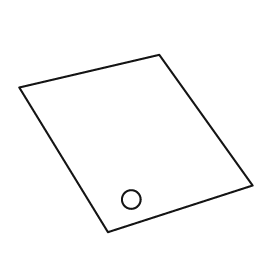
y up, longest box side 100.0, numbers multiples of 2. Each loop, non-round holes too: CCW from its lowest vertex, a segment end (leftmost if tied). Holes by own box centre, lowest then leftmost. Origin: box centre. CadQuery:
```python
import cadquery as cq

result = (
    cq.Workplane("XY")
    .moveTo(-12.0, -38.0)
    .lineTo(50.0, -18.0)
    .lineTo(10.0, 38.0)
    .lineTo(-50.0, 24.0)
    .close()
    .moveTo(-2.0, -24.0)
    .circle(4.0)
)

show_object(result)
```